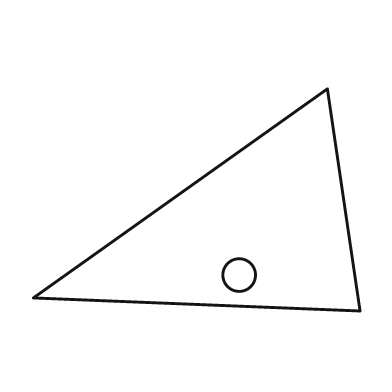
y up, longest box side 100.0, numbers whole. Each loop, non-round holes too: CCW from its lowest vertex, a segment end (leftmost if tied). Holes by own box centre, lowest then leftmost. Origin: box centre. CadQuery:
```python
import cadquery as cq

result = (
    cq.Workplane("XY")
    .moveTo(50.0, -34.0)
    .lineTo(40.0, 34.0)
    .lineTo(-50.0, -30.0)
    .close()
    .moveTo(13.0, -23.0)
    .circle(5.0)
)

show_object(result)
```